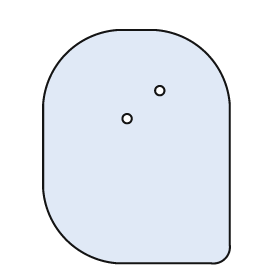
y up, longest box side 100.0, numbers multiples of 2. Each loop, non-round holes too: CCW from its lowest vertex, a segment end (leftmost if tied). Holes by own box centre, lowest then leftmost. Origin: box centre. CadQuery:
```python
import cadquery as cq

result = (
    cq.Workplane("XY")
    .moveTo(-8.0, -50.0)
    .lineTo(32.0, -50.0)
    .threePointArc((38.0, -48.0), (40.0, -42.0))
    .lineTo(40.0, 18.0)
    .threePointArc((30.0, 40.0), (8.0, 50.0))
    .lineTo(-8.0, 50.0)
    .threePointArc((-30.0, 40.0), (-40.0, 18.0))
    .lineTo(-40.0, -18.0)
    .threePointArc((-30.0, -40.0), (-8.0, -50.0))
    .close()
    .moveTo(-4.0, 12.0)
    .circle(2.0)
    .moveTo(10.0, 24.0)
    .circle(2.0)
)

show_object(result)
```